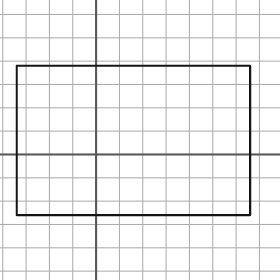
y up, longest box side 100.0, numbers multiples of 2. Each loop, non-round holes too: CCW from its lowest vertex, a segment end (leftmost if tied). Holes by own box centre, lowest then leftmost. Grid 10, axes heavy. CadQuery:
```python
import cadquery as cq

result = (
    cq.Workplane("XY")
    .moveTo(-34.0, -26.0)
    .lineTo(66.0, -26.0)
    .lineTo(66.0, 38.0)
    .lineTo(-34.0, 38.0)
    .close()
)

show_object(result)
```